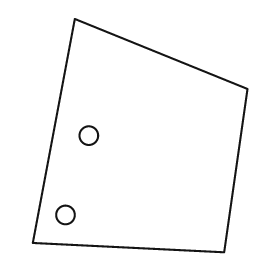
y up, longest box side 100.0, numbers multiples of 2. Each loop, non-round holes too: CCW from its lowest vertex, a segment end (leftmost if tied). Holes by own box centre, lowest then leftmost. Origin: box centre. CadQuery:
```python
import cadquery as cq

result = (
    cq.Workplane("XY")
    .moveTo(36.0, -50.0)
    .lineTo(46.0, 20.0)
    .lineTo(-28.0, 50.0)
    .lineTo(-46.0, -46.0)
    .close()
    .moveTo(-32.0, -34.0)
    .circle(4.0)
    .moveTo(-22.0, 0.0)
    .circle(4.0)
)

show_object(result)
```